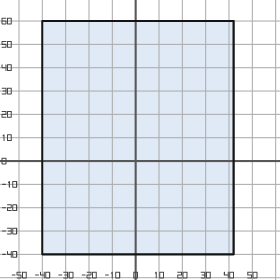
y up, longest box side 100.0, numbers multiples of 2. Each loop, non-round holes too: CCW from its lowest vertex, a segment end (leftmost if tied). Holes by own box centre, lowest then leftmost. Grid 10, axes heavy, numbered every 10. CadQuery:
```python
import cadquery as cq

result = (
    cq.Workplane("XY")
    .moveTo(-40.0, -40.0)
    .lineTo(42.0, -40.0)
    .lineTo(42.0, 60.0)
    .lineTo(-40.0, 60.0)
    .close()
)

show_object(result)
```